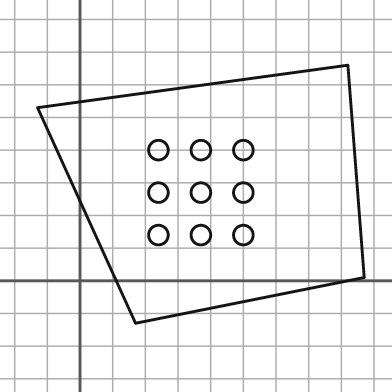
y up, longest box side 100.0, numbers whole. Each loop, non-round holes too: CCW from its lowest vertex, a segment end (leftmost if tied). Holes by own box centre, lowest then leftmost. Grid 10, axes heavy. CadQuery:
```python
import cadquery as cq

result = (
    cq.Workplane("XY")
    .moveTo(17.0, -13.0)
    .lineTo(87.0, 1.0)
    .lineTo(82.0, 66.0)
    .lineTo(-13.0, 53.0)
    .close()
    .moveTo(24.0, 14.0)
    .circle(3.0)
    .moveTo(37.0, 14.0)
    .circle(3.0)
    .moveTo(50.0, 14.0)
    .circle(3.0)
    .moveTo(24.0, 27.0)
    .circle(3.0)
    .moveTo(37.0, 27.0)
    .circle(3.0)
    .moveTo(50.0, 27.0)
    .circle(3.0)
    .moveTo(24.0, 40.0)
    .circle(3.0)
    .moveTo(37.0, 40.0)
    .circle(3.0)
    .moveTo(50.0, 40.0)
    .circle(3.0)
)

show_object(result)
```